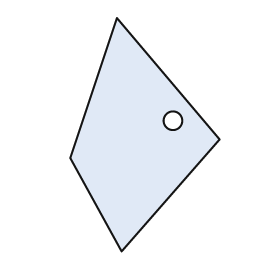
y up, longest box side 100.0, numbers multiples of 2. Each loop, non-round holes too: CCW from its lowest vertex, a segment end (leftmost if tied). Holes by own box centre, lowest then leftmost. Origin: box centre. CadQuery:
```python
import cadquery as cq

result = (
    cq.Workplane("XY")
    .moveTo(-10.0, -50.0)
    .lineTo(32.0, -2.0)
    .lineTo(-12.0, 50.0)
    .lineTo(-32.0, -10.0)
    .close()
    .moveTo(12.0, 6.0)
    .circle(4.0)
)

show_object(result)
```